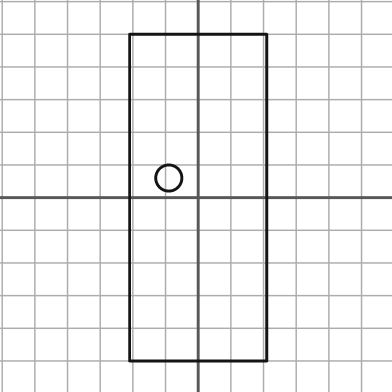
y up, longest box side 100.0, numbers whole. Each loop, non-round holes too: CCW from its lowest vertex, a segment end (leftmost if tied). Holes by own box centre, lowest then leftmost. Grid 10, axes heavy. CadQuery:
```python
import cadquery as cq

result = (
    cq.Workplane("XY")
    .moveTo(-21.0, -50.0)
    .lineTo(21.0, -50.0)
    .lineTo(21.0, 50.0)
    .lineTo(-21.0, 50.0)
    .close()
    .moveTo(-9.0, 6.0)
    .circle(4.0)
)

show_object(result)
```